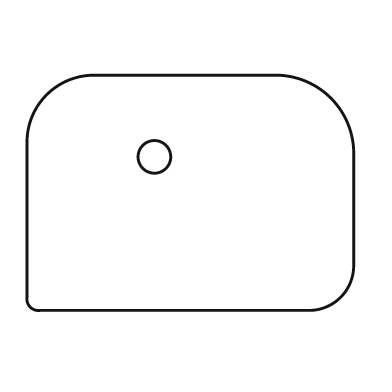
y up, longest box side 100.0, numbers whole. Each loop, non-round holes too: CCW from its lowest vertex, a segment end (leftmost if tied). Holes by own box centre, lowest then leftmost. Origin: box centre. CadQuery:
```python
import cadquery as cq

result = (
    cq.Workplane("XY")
    .moveTo(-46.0, -36.0)
    .lineTo(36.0, -36.0)
    .threePointArc((46.0, -32.0), (50.0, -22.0))
    .lineTo(50.0, 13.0)
    .threePointArc((43.0, 29.0), (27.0, 36.0))
    .lineTo(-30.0, 36.0)
    .threePointArc((-44.0, 30.0), (-50.0, 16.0))
    .lineTo(-50.0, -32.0)
    .threePointArc((-49.0, -35.0), (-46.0, -36.0))
    .close()
    .moveTo(-11.0, 11.0)
    .circle(5.0)
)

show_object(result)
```